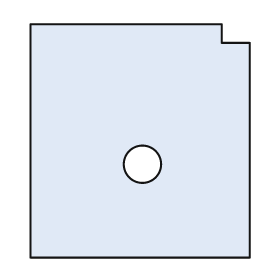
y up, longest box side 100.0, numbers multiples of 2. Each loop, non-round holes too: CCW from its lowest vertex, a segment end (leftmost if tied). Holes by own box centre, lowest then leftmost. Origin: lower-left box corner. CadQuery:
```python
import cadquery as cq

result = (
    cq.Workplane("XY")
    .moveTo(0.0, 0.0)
    .lineTo(94.0, 0.0)
    .lineTo(94.0, 92.0)
    .lineTo(82.0, 92.0)
    .lineTo(82.0, 100.0)
    .lineTo(0.0, 100.0)
    .close()
    .moveTo(48.0, 40.0)
    .circle(8.0)
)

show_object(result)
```